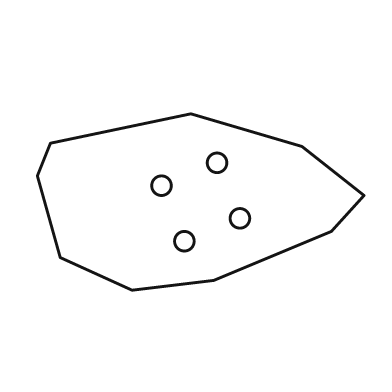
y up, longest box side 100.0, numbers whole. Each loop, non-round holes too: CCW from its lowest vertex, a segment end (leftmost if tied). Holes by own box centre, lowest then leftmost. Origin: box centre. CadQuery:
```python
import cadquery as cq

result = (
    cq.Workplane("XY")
    .moveTo(-21.0, -27.0)
    .lineTo(4.0, -24.0)
    .lineTo(40.0, -9.0)
    .lineTo(50.0, 2.0)
    .lineTo(31.0, 17.0)
    .lineTo(-3.0, 27.0)
    .lineTo(-46.0, 18.0)
    .lineTo(-50.0, 8.0)
    .lineTo(-43.0, -17.0)
    .close()
    .moveTo(-5.0, -12.0)
    .circle(3.0)
    .moveTo(12.0, -5.0)
    .circle(3.0)
    .moveTo(-12.0, 5.0)
    .circle(3.0)
    .moveTo(5.0, 12.0)
    .circle(3.0)
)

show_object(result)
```